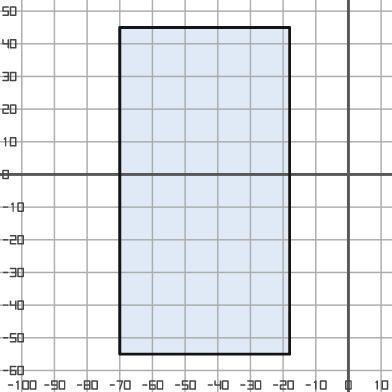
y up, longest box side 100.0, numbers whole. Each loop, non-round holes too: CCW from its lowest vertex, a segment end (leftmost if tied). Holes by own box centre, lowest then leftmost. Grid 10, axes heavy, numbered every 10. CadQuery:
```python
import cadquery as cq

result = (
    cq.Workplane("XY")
    .moveTo(-70.0, -55.0)
    .lineTo(-18.0, -55.0)
    .lineTo(-18.0, 45.0)
    .lineTo(-70.0, 45.0)
    .close()
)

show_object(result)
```